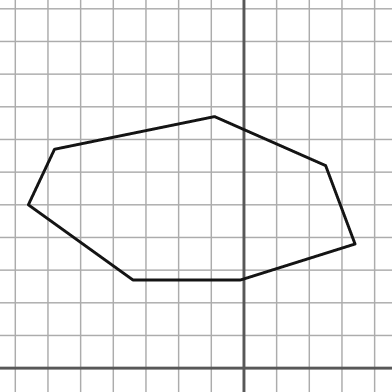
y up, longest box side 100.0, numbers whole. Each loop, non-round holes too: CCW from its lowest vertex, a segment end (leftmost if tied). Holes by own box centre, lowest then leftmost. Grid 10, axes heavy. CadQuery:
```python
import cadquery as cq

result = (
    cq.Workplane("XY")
    .moveTo(-34.0, 27.0)
    .lineTo(-1.0, 27.0)
    .lineTo(34.0, 38.0)
    .lineTo(25.0, 62.0)
    .lineTo(-9.0, 77.0)
    .lineTo(-58.0, 67.0)
    .lineTo(-66.0, 50.0)
    .close()
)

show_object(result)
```